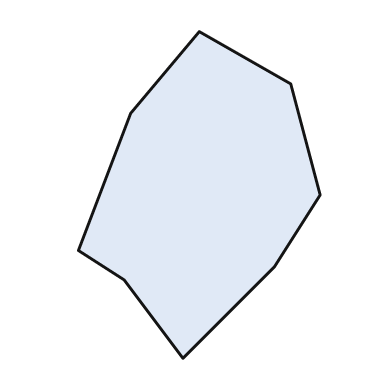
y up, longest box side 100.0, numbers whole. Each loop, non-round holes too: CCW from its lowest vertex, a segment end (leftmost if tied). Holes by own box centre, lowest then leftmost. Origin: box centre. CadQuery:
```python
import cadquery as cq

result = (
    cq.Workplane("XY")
    .moveTo(-5.0, -50.0)
    .lineTo(23.0, -22.0)
    .lineTo(37.0, 0.0)
    .lineTo(28.0, 34.0)
    .lineTo(0.0, 50.0)
    .lineTo(-21.0, 25.0)
    .lineTo(-37.0, -17.0)
    .lineTo(-23.0, -26.0)
    .close()
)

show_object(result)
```